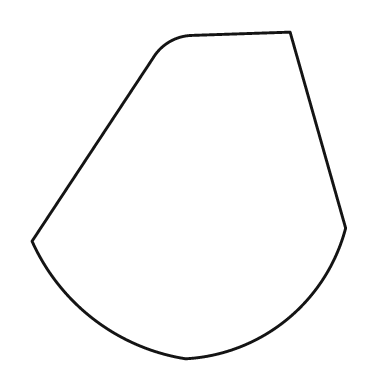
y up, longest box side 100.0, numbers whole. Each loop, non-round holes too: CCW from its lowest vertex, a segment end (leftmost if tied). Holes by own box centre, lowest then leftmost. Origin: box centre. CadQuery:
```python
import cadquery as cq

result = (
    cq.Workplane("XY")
    .moveTo(-1.0, -50.0)
    .threePointArc((30.0, -38.0), (48.0, -10.0))
    .lineTo(31.0, 50.0)
    .lineTo(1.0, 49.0)
    .threePointArc((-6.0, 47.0), (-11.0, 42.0))
    .lineTo(-48.0, -14.0)
    .threePointArc((-29.0, -38.0), (-1.0, -50.0))
    .close()
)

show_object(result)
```